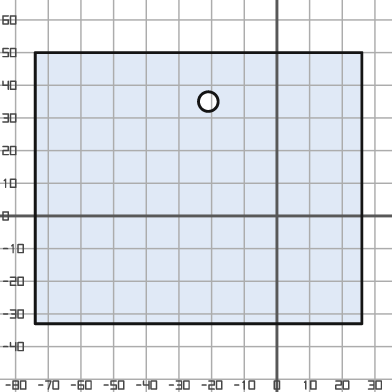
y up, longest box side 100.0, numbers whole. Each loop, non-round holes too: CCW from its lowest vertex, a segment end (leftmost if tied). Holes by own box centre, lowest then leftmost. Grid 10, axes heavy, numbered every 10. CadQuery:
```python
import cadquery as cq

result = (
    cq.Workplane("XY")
    .moveTo(-74.0, -33.0)
    .lineTo(26.0, -33.0)
    .lineTo(26.0, 50.0)
    .lineTo(-74.0, 50.0)
    .close()
    .moveTo(-21.0, 35.0)
    .circle(3.0)
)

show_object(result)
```